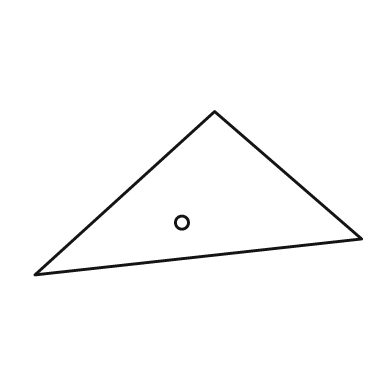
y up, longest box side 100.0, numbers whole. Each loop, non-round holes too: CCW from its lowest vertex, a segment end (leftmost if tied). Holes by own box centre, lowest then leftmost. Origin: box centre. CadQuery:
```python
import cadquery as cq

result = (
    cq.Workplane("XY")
    .moveTo(-50.0, -25.0)
    .lineTo(50.0, -14.0)
    .lineTo(5.0, 25.0)
    .close()
    .moveTo(-5.0, -9.0)
    .circle(2.0)
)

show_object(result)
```